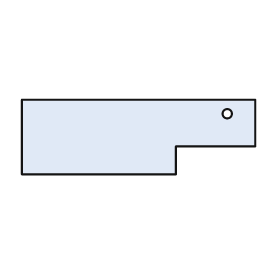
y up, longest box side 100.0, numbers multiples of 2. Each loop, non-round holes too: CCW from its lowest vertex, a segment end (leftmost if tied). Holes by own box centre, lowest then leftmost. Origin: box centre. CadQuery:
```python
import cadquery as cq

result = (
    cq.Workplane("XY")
    .moveTo(-50.0, -16.0)
    .lineTo(16.0, -16.0)
    .lineTo(16.0, -4.0)
    .lineTo(50.0, -4.0)
    .lineTo(50.0, 16.0)
    .lineTo(-50.0, 16.0)
    .close()
    .moveTo(38.0, 10.0)
    .circle(2.0)
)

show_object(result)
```